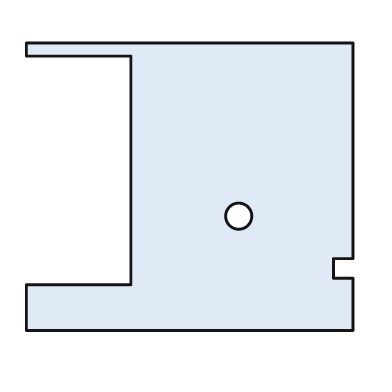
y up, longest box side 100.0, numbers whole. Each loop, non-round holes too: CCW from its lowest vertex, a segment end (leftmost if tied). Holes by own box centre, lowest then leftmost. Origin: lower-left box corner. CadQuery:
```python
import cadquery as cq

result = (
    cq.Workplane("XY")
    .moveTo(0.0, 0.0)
    .lineTo(100.0, 0.0)
    .lineTo(100.0, 16.0)
    .lineTo(94.0, 16.0)
    .lineTo(94.0, 22.0)
    .lineTo(100.0, 22.0)
    .lineTo(100.0, 88.0)
    .lineTo(0.0, 88.0)
    .lineTo(0.0, 84.0)
    .lineTo(32.0, 84.0)
    .lineTo(32.0, 14.0)
    .lineTo(0.0, 14.0)
    .close()
    .moveTo(65.0, 35.0)
    .circle(4.0)
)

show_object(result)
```